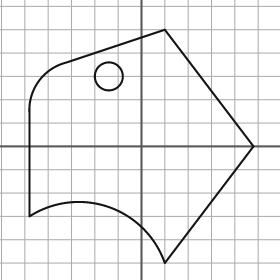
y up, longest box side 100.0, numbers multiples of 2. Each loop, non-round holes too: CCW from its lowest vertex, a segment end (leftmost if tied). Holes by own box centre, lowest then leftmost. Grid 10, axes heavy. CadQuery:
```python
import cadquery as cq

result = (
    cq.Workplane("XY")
    .moveTo(10.0, -50.0)
    .lineTo(48.0, 0.0)
    .lineTo(10.0, 50.0)
    .lineTo(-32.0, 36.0)
    .threePointArc((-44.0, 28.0), (-48.0, 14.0))
    .lineTo(-48.0, -30.0)
    .threePointArc((-14.0, -26.0), (10.0, -50.0))
    .close()
    .moveTo(-14.0, 30.0)
    .circle(6.0)
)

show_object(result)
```